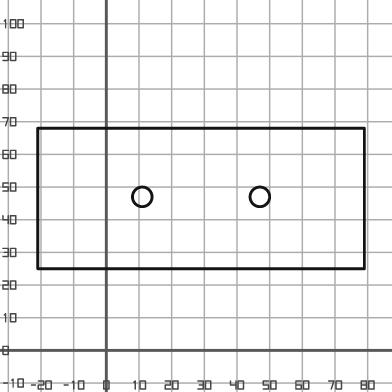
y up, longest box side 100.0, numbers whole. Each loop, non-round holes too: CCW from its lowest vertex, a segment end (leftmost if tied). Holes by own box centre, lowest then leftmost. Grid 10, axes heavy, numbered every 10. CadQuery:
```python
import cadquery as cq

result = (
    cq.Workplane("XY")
    .moveTo(-21.0, 25.0)
    .lineTo(79.0, 25.0)
    .lineTo(79.0, 68.0)
    .lineTo(-21.0, 68.0)
    .close()
    .moveTo(11.0, 47.0)
    .circle(3.0)
    .moveTo(47.0, 47.0)
    .circle(3.0)
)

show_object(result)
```